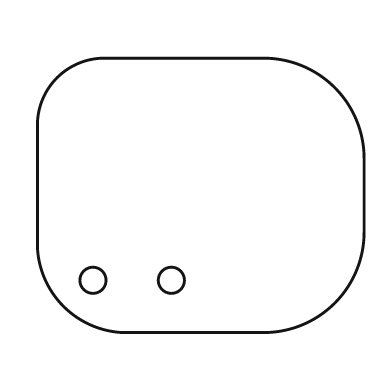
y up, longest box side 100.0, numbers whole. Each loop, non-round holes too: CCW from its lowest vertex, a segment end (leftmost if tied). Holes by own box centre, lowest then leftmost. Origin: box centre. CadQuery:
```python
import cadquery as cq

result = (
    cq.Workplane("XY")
    .moveTo(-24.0, -42.0)
    .lineTo(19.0, -42.0)
    .threePointArc((41.0, -33.0), (50.0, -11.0))
    .lineTo(50.0, 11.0)
    .threePointArc((41.0, 33.0), (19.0, 42.0))
    .lineTo(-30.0, 42.0)
    .threePointArc((-44.0, 36.0), (-50.0, 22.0))
    .lineTo(-50.0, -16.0)
    .threePointArc((-42.0, -34.0), (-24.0, -42.0))
    .close()
    .moveTo(-33.0, -26.0)
    .circle(4.0)
    .moveTo(-9.0, -26.0)
    .circle(4.0)
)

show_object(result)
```